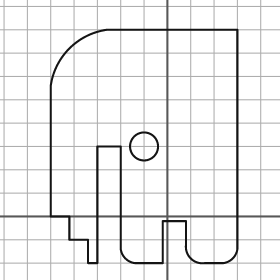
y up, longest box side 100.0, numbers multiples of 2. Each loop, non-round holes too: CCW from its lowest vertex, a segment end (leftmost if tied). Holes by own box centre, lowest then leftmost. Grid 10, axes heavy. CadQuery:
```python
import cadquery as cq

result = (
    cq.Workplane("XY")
    .moveTo(-34.0, -20.0)
    .lineTo(-30.0, -20.0)
    .lineTo(-30.0, 30.0)
    .lineTo(-20.0, 30.0)
    .lineTo(-20.0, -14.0)
    .threePointArc((-18.0, -18.0), (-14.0, -20.0))
    .lineTo(-2.0, -20.0)
    .lineTo(-2.0, -2.0)
    .lineTo(8.0, -2.0)
    .lineTo(8.0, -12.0)
    .threePointArc((10.0, -18.0), (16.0, -20.0))
    .lineTo(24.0, -20.0)
    .threePointArc((28.0, -18.0), (30.0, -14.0))
    .lineTo(30.0, 80.0)
    .lineTo(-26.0, 80.0)
    .threePointArc((-42.0, 72.0), (-50.0, 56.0))
    .lineTo(-50.0, 0.0)
    .lineTo(-42.0, 0.0)
    .lineTo(-42.0, -10.0)
    .lineTo(-34.0, -10.0)
    .close()
    .moveTo(-10.0, 30.0)
    .circle(6.0)
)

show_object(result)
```